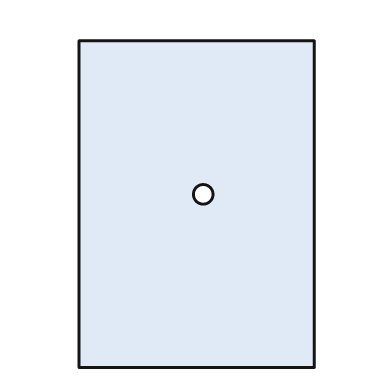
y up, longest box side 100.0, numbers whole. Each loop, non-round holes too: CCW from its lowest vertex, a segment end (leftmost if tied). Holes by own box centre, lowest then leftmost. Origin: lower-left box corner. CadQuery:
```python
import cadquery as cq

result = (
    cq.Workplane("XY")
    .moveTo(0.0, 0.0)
    .lineTo(72.0, 0.0)
    .lineTo(72.0, 100.0)
    .lineTo(0.0, 100.0)
    .close()
    .moveTo(38.0, 53.0)
    .circle(3.0)
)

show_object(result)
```